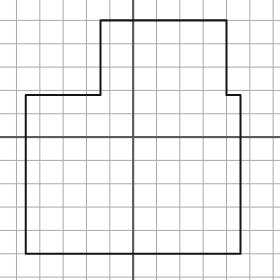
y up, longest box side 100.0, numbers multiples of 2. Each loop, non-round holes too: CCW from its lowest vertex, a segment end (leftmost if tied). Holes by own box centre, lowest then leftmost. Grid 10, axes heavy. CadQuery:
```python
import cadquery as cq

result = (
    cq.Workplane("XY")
    .moveTo(-46.0, -50.0)
    .lineTo(46.0, -50.0)
    .lineTo(46.0, 18.0)
    .lineTo(40.0, 18.0)
    .lineTo(40.0, 50.0)
    .lineTo(-14.0, 50.0)
    .lineTo(-14.0, 18.0)
    .lineTo(-46.0, 18.0)
    .close()
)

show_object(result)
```